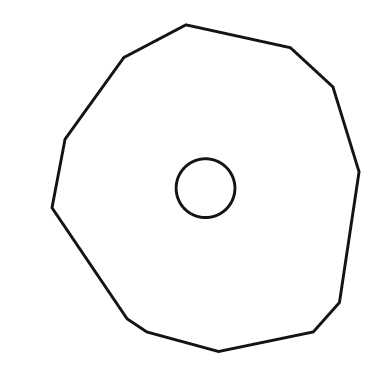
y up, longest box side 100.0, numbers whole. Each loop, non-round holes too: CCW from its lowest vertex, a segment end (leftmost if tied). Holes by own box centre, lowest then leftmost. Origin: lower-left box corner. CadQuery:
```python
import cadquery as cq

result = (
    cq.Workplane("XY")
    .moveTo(51.0, 0.0)
    .lineTo(80.0, 6.0)
    .lineTo(88.0, 15.0)
    .lineTo(94.0, 55.0)
    .lineTo(86.0, 81.0)
    .lineTo(73.0, 93.0)
    .lineTo(41.0, 100.0)
    .lineTo(22.0, 90.0)
    .lineTo(4.0, 65.0)
    .lineTo(0.0, 44.0)
    .lineTo(23.0, 10.0)
    .lineTo(29.0, 6.0)
    .close()
    .moveTo(47.0, 50.0)
    .circle(9.0)
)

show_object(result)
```